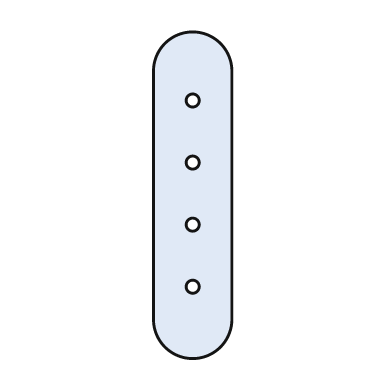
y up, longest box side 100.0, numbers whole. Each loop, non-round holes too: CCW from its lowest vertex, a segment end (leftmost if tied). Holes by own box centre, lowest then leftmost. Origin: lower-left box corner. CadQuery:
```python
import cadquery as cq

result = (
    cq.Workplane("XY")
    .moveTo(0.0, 12.0)
    .threePointArc((12.0, 0.0), (24.0, 12.0))
    .lineTo(24.0, 88.0)
    .threePointArc((12.0, 100.0), (0.0, 88.0))
    .close()
    .moveTo(12.0, 22.0)
    .circle(2.0)
    .moveTo(12.0, 41.0)
    .circle(2.0)
    .moveTo(12.0, 60.0)
    .circle(2.0)
    .moveTo(12.0, 79.0)
    .circle(2.0)
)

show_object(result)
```